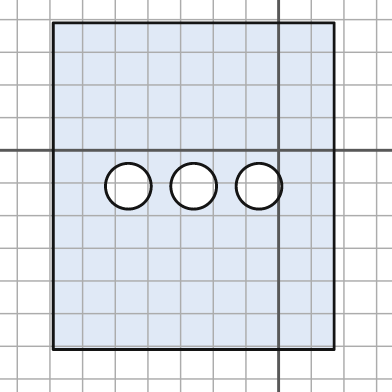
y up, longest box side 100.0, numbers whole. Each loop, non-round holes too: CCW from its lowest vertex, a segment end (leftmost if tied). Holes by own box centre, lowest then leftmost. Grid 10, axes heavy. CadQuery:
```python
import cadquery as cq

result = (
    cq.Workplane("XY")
    .moveTo(-69.0, -61.0)
    .lineTo(17.0, -61.0)
    .lineTo(17.0, 39.0)
    .lineTo(-69.0, 39.0)
    .close()
    .moveTo(-46.0, -11.0)
    .circle(7.0)
    .moveTo(-26.0, -11.0)
    .circle(7.0)
    .moveTo(-6.0, -11.0)
    .circle(7.0)
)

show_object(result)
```